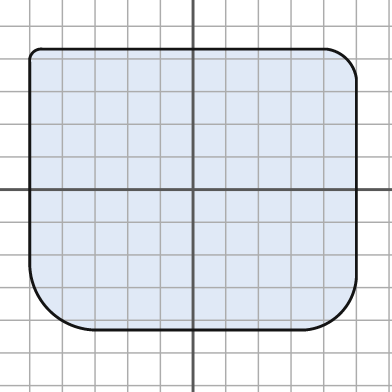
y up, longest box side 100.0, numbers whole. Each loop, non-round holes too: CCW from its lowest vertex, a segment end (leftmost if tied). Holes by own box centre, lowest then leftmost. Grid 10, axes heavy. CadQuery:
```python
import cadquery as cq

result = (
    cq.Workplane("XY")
    .moveTo(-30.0, -43.0)
    .lineTo(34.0, -43.0)
    .threePointArc((45.0, -38.0), (50.0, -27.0))
    .lineTo(50.0, 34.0)
    .threePointArc((47.0, 40.0), (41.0, 43.0))
    .lineTo(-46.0, 43.0)
    .threePointArc((-49.0, 42.0), (-50.0, 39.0))
    .lineTo(-50.0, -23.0)
    .threePointArc((-44.0, -37.0), (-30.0, -43.0))
    .close()
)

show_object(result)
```